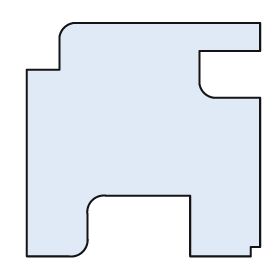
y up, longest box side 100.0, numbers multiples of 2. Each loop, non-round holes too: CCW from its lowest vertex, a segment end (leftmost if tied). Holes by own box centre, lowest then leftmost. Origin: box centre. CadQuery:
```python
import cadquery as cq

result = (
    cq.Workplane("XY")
    .moveTo(-50.0, -50.0)
    .lineTo(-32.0, -50.0)
    .threePointArc((-26.0, -48.0), (-24.0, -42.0))
    .lineTo(-24.0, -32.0)
    .threePointArc((-22.0, -26.0), (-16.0, -24.0))
    .lineTo(20.0, -24.0)
    .lineTo(20.0, -50.0)
    .lineTo(46.0, -50.0)
    .lineTo(46.0, -46.0)
    .lineTo(50.0, -46.0)
    .lineTo(50.0, 18.0)
    .lineTo(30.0, 18.0)
    .threePointArc((26.0, 20.0), (24.0, 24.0))
    .lineTo(24.0, 38.0)
    .lineTo(50.0, 38.0)
    .lineTo(50.0, 50.0)
    .lineTo(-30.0, 50.0)
    .threePointArc((-34.0, 48.0), (-36.0, 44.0))
    .lineTo(-36.0, 30.0)
    .lineTo(-50.0, 30.0)
    .close()
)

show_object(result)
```